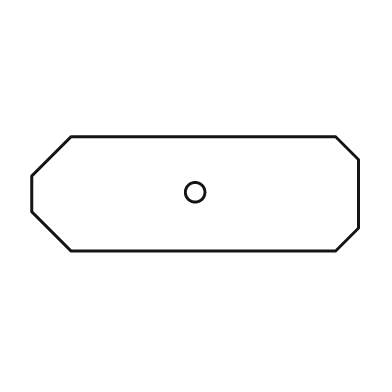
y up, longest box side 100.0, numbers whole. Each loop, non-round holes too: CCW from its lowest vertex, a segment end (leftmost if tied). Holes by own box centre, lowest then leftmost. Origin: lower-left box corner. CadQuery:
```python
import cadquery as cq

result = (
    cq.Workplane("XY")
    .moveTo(12.0, 0.0)
    .lineTo(93.0, 0.0)
    .lineTo(100.0, 7.0)
    .lineTo(100.0, 28.0)
    .lineTo(93.0, 35.0)
    .lineTo(12.0, 35.0)
    .lineTo(0.0, 23.0)
    .lineTo(0.0, 12.0)
    .close()
    .moveTo(50.0, 18.0)
    .circle(3.0)
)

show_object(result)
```